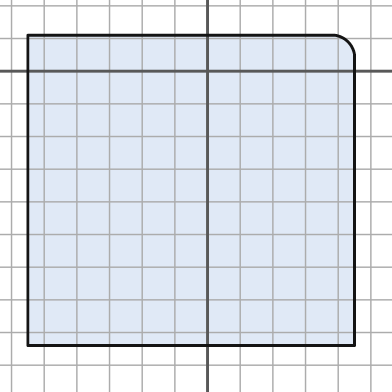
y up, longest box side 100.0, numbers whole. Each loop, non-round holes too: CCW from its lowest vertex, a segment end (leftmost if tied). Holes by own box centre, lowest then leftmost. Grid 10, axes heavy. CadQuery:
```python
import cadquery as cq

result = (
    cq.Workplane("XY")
    .moveTo(-55.0, -84.0)
    .lineTo(45.0, -84.0)
    .lineTo(45.0, 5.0)
    .threePointArc((43.0, 9.0), (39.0, 11.0))
    .lineTo(-55.0, 11.0)
    .close()
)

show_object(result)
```